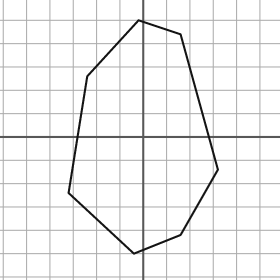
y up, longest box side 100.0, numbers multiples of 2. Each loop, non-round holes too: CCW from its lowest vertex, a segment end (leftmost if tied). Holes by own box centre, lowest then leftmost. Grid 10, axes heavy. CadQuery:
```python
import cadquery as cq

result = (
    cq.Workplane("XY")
    .moveTo(-4.0, -50.0)
    .lineTo(16.0, -42.0)
    .lineTo(32.0, -14.0)
    .lineTo(16.0, 44.0)
    .lineTo(-2.0, 50.0)
    .lineTo(-24.0, 26.0)
    .lineTo(-32.0, -24.0)
    .close()
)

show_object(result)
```